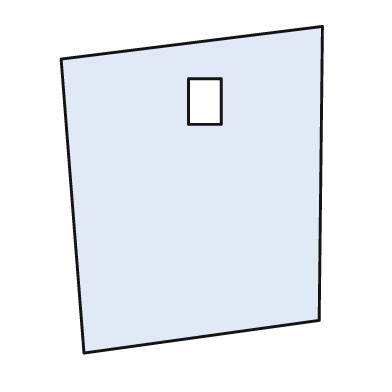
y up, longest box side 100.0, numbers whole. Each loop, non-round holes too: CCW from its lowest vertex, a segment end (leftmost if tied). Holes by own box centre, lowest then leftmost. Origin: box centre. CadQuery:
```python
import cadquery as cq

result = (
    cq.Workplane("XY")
    .moveTo(-33.0, -50.0)
    .lineTo(39.0, -40.0)
    .lineTo(40.0, 50.0)
    .lineTo(-40.0, 40.0)
    .close()
    .moveTo(-1.0, 20.0)
    .lineTo(9.0, 20.0)
    .lineTo(9.0, 34.0)
    .lineTo(-1.0, 34.0)
    .close()
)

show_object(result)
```